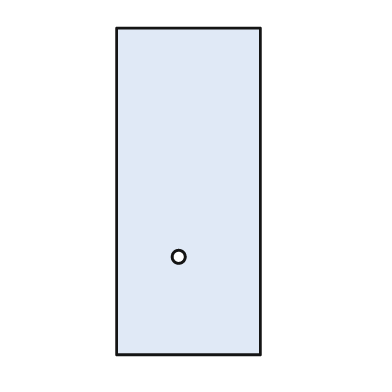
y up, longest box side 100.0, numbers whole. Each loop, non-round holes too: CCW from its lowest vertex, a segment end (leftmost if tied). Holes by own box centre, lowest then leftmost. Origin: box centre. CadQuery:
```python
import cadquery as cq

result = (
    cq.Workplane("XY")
    .moveTo(-22.0, -50.0)
    .lineTo(22.0, -50.0)
    .lineTo(22.0, 50.0)
    .lineTo(-22.0, 50.0)
    .close()
    .moveTo(-3.0, -20.0)
    .circle(2.0)
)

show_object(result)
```